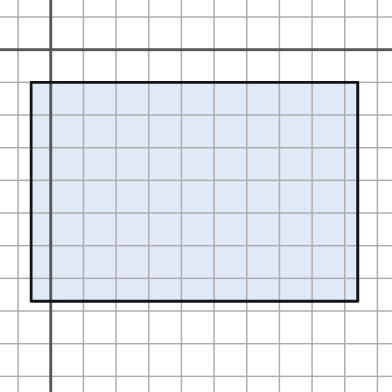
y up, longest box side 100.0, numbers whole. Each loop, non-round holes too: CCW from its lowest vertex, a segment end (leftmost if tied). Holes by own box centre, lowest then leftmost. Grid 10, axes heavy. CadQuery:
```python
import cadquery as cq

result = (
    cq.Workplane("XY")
    .moveTo(-6.0, -77.0)
    .lineTo(94.0, -77.0)
    .lineTo(94.0, -10.0)
    .lineTo(-6.0, -10.0)
    .close()
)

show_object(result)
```